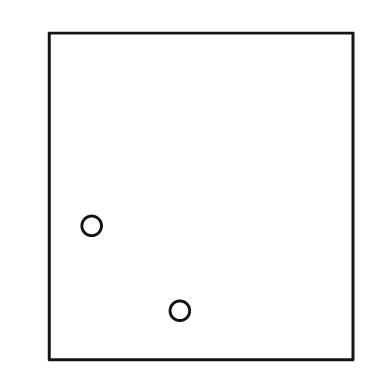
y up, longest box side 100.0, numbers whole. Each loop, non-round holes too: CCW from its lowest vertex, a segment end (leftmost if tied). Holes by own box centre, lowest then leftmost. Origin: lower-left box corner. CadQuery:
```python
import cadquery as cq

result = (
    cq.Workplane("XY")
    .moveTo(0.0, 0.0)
    .lineTo(93.0, 0.0)
    .lineTo(93.0, 100.0)
    .lineTo(0.0, 100.0)
    .close()
    .moveTo(40.0, 15.0)
    .circle(3.0)
    .moveTo(13.0, 41.0)
    .circle(3.0)
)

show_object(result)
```